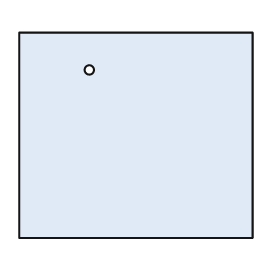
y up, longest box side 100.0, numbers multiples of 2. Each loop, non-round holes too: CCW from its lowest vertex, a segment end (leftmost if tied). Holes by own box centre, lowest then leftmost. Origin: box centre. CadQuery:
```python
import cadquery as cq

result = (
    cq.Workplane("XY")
    .moveTo(-50.0, -44.0)
    .lineTo(50.0, -44.0)
    .lineTo(50.0, 44.0)
    .lineTo(-50.0, 44.0)
    .close()
    .moveTo(-20.0, 28.0)
    .circle(2.0)
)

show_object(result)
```